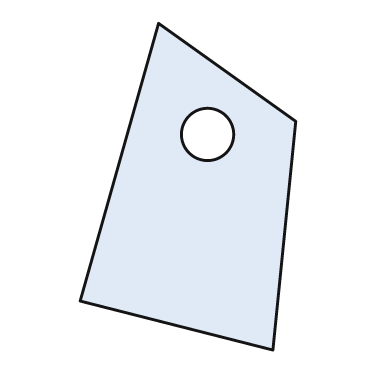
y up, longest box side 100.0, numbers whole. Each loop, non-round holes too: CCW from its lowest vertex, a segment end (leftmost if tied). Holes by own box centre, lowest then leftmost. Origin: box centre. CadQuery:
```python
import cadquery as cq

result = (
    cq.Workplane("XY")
    .moveTo(26.0, -50.0)
    .lineTo(33.0, 20.0)
    .lineTo(-9.0, 50.0)
    .lineTo(-33.0, -35.0)
    .close()
    .moveTo(6.0, 16.0)
    .circle(8.0)
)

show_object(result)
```